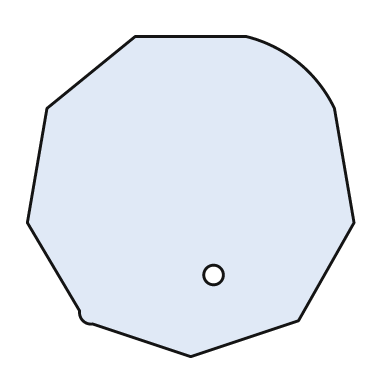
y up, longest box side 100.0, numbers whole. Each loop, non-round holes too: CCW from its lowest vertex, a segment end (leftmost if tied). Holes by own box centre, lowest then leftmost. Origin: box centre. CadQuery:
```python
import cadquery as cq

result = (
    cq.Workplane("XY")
    .moveTo(0.0, -49.0)
    .lineTo(33.0, -38.0)
    .lineTo(50.0, -8.0)
    .lineTo(44.0, 27.0)
    .threePointArc((33.0, 41.0), (17.0, 49.0))
    .lineTo(-17.0, 49.0)
    .lineTo(-44.0, 27.0)
    .lineTo(-50.0, -8.0)
    .lineTo(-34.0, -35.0)
    .threePointArc((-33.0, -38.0), (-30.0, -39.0))
    .close()
    .moveTo(7.0, -24.0)
    .circle(3.0)
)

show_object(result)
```